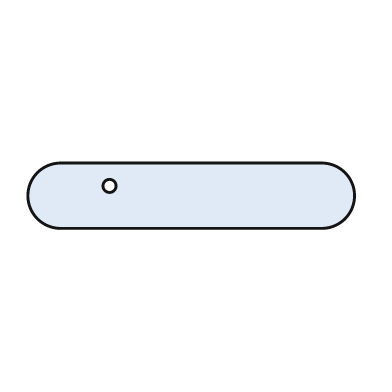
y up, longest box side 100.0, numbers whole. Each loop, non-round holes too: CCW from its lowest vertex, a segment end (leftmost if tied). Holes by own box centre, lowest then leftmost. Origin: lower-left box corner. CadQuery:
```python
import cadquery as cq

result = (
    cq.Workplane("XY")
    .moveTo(10.0, 0.0)
    .lineTo(90.0, 0.0)
    .threePointArc((100.0, 10.0), (90.0, 20.0))
    .lineTo(10.0, 20.0)
    .threePointArc((0.0, 10.0), (10.0, 0.0))
    .close()
    .moveTo(25.0, 13.0)
    .circle(2.0)
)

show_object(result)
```